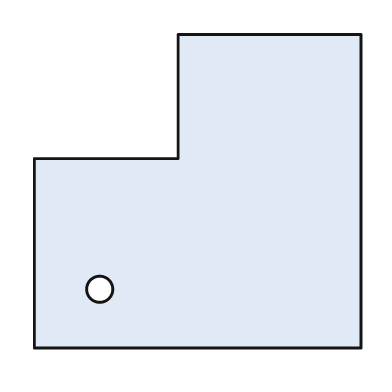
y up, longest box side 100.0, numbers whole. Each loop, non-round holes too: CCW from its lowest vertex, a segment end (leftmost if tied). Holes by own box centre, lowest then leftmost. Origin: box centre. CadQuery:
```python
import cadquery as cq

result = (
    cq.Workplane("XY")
    .moveTo(-50.0, -48.0)
    .lineTo(50.0, -48.0)
    .lineTo(50.0, 48.0)
    .lineTo(-6.0, 48.0)
    .lineTo(-6.0, 10.0)
    .lineTo(-50.0, 10.0)
    .close()
    .moveTo(-30.0, -30.0)
    .circle(4.0)
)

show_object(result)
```